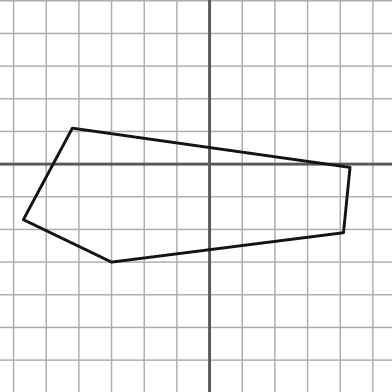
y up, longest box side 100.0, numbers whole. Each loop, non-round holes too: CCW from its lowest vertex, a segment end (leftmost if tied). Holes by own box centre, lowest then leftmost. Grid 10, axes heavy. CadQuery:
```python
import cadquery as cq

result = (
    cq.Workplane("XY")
    .moveTo(-30.0, -30.0)
    .lineTo(41.0, -21.0)
    .lineTo(43.0, -1.0)
    .lineTo(-42.0, 11.0)
    .lineTo(-57.0, -17.0)
    .close()
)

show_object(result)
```